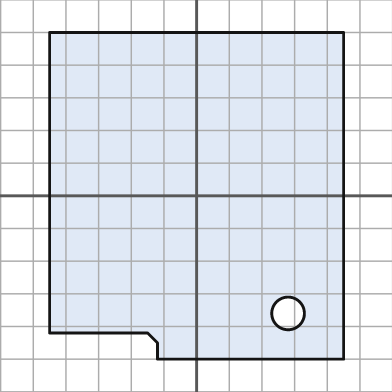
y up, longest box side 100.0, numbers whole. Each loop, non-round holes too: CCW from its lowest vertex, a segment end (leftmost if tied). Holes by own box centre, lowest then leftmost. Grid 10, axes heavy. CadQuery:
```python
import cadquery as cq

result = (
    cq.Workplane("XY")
    .moveTo(-12.0, -50.0)
    .lineTo(45.0, -50.0)
    .lineTo(45.0, 50.0)
    .lineTo(-45.0, 50.0)
    .lineTo(-45.0, -42.0)
    .lineTo(-15.0, -42.0)
    .lineTo(-12.0, -45.0)
    .close()
    .moveTo(28.0, -36.0)
    .circle(5.0)
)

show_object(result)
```